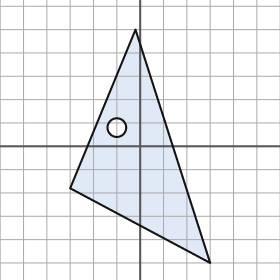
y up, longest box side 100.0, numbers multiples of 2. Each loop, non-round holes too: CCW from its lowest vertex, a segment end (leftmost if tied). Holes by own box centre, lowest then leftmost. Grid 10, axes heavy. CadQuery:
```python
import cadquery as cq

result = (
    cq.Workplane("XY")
    .moveTo(30.0, -50.0)
    .lineTo(-2.0, 50.0)
    .lineTo(-30.0, -18.0)
    .close()
    .moveTo(-10.0, 8.0)
    .circle(4.0)
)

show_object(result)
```